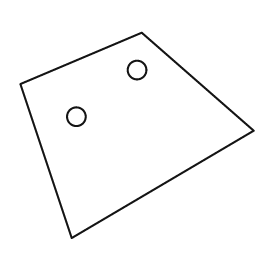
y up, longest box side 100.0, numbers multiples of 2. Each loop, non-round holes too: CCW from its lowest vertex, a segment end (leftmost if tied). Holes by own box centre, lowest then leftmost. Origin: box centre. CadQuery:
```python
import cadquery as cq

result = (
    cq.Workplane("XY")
    .moveTo(-28.0, -44.0)
    .lineTo(50.0, 2.0)
    .lineTo(2.0, 44.0)
    .lineTo(-50.0, 22.0)
    .close()
    .moveTo(-26.0, 8.0)
    .circle(4.0)
    .moveTo(0.0, 28.0)
    .circle(4.0)
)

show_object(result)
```